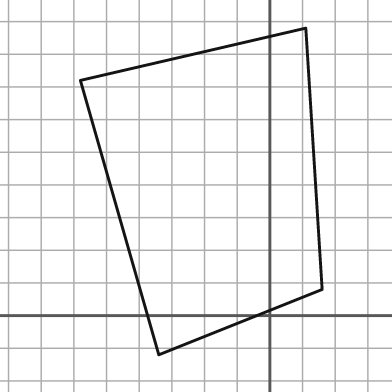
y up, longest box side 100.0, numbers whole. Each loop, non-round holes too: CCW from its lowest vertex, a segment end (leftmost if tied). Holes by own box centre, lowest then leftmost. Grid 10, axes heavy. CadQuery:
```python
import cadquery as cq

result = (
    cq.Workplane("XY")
    .moveTo(-34.0, -12.0)
    .lineTo(16.0, 8.0)
    .lineTo(11.0, 88.0)
    .lineTo(-58.0, 72.0)
    .close()
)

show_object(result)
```